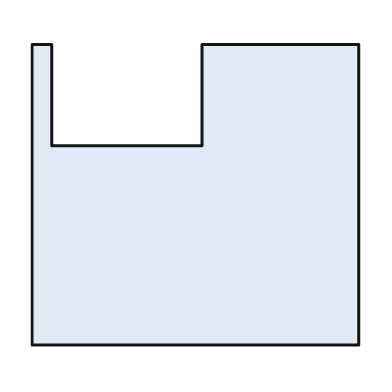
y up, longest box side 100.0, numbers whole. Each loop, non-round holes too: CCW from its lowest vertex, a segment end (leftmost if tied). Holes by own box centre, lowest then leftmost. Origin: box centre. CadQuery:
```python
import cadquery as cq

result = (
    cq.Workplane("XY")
    .moveTo(-50.0, -46.0)
    .lineTo(50.0, -46.0)
    .lineTo(50.0, 46.0)
    .lineTo(2.0, 46.0)
    .lineTo(2.0, 15.0)
    .lineTo(-44.0, 15.0)
    .lineTo(-44.0, 46.0)
    .lineTo(-50.0, 46.0)
    .close()
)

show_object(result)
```